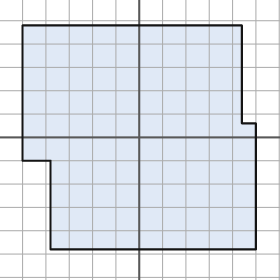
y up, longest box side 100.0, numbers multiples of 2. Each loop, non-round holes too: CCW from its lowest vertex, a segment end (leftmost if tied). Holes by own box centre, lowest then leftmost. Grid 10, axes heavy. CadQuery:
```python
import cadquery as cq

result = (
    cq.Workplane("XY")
    .moveTo(-38.0, -48.0)
    .lineTo(50.0, -48.0)
    .lineTo(50.0, 6.0)
    .lineTo(44.0, 6.0)
    .lineTo(44.0, 48.0)
    .lineTo(-50.0, 48.0)
    .lineTo(-50.0, -10.0)
    .lineTo(-38.0, -10.0)
    .close()
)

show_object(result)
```